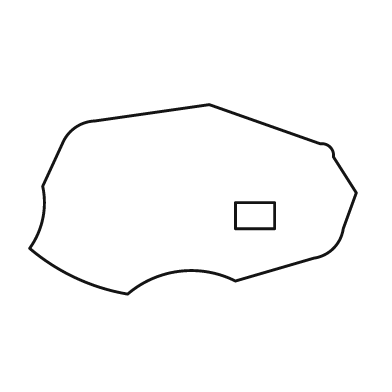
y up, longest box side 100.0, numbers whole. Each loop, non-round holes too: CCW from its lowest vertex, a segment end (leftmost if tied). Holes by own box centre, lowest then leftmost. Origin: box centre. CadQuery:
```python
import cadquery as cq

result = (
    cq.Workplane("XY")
    .moveTo(-20.0, -29.0)
    .threePointArc((-4.0, -22.0), (13.0, -25.0))
    .lineTo(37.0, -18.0)
    .threePointArc((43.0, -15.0), (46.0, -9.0))
    .lineTo(50.0, 2.0)
    .lineTo(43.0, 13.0)
    .threePointArc((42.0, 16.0), (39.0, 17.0))
    .lineTo(5.0, 29.0)
    .lineTo(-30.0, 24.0)
    .threePointArc((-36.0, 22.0), (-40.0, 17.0))
    .lineTo(-46.0, 4.0)
    .threePointArc((-46.0, -6.0), (-50.0, -15.0))
    .threePointArc((-36.0, -24.0), (-20.0, -29.0))
    .close()
    .moveTo(13.0, -9.0)
    .lineTo(25.0, -9.0)
    .lineTo(25.0, -1.0)
    .lineTo(13.0, -1.0)
    .close()
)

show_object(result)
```